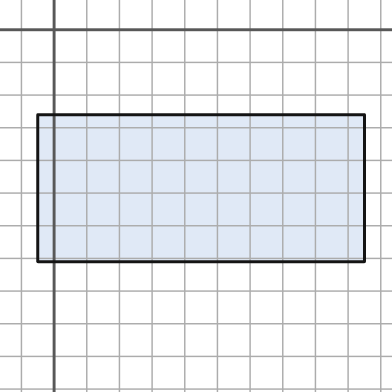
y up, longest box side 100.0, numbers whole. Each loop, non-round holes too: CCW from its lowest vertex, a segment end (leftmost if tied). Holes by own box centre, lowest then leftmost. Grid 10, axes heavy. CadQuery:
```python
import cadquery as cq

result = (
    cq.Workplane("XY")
    .moveTo(-5.0, -71.0)
    .lineTo(95.0, -71.0)
    .lineTo(95.0, -26.0)
    .lineTo(-5.0, -26.0)
    .close()
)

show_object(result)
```